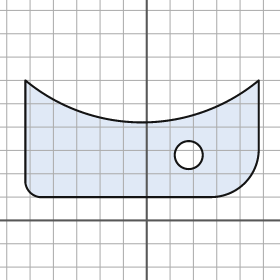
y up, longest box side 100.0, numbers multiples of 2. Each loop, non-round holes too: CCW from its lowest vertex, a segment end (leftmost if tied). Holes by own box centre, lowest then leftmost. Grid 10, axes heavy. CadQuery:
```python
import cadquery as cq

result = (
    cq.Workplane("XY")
    .moveTo(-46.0, 10.0)
    .lineTo(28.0, 10.0)
    .threePointArc((42.0, 16.0), (48.0, 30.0))
    .lineTo(48.0, 60.0)
    .threePointArc((-2.0, 42.0), (-52.0, 60.0))
    .lineTo(-52.0, 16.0)
    .threePointArc((-50.0, 12.0), (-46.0, 10.0))
    .close()
    .moveTo(18.0, 28.0)
    .circle(6.0)
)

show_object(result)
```